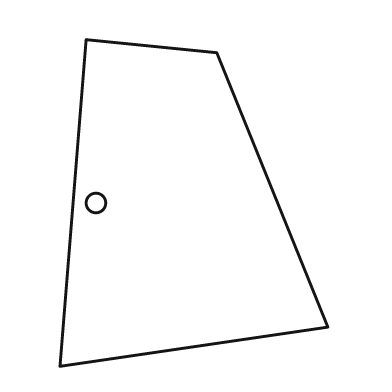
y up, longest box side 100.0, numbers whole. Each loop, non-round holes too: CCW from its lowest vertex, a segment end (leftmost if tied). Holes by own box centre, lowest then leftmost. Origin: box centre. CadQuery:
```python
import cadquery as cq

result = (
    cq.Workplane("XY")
    .moveTo(-41.0, -50.0)
    .lineTo(41.0, -38.0)
    .lineTo(7.0, 46.0)
    .lineTo(-33.0, 50.0)
    .close()
    .moveTo(-30.0, 0.0)
    .circle(3.0)
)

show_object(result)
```